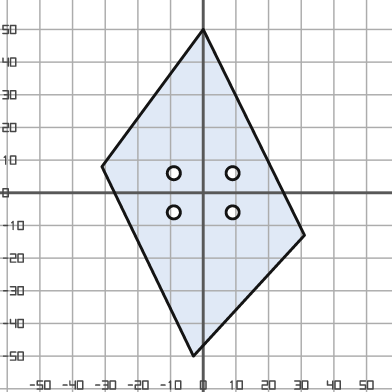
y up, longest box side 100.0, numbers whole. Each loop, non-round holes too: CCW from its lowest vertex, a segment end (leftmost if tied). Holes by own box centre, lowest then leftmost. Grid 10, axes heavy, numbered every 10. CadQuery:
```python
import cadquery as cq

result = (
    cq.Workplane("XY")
    .moveTo(-3.0, -50.0)
    .lineTo(31.0, -13.0)
    .lineTo(0.0, 50.0)
    .lineTo(-31.0, 8.0)
    .close()
    .moveTo(-9.0, -6.0)
    .circle(2.0)
    .moveTo(9.0, -6.0)
    .circle(2.0)
    .moveTo(-9.0, 6.0)
    .circle(2.0)
    .moveTo(9.0, 6.0)
    .circle(2.0)
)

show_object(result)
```